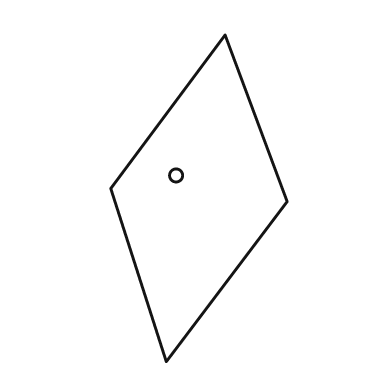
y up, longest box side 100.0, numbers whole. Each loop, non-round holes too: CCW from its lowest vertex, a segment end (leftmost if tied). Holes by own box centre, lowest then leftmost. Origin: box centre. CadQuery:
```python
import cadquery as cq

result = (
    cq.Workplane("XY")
    .moveTo(-10.0, -50.0)
    .lineTo(27.0, -1.0)
    .lineTo(8.0, 50.0)
    .lineTo(-27.0, 3.0)
    .close()
    .moveTo(-7.0, 7.0)
    .circle(2.0)
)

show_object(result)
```